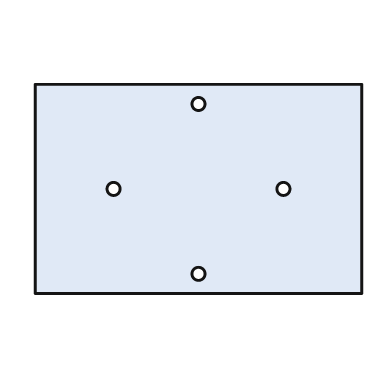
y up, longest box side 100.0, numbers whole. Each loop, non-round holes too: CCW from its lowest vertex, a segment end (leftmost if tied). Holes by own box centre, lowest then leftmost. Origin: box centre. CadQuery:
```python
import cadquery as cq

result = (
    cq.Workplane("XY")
    .moveTo(-50.0, -32.0)
    .lineTo(50.0, -32.0)
    .lineTo(50.0, 32.0)
    .lineTo(-50.0, 32.0)
    .close()
    .moveTo(0.0, -26.0)
    .circle(2.0)
    .moveTo(-26.0, 0.0)
    .circle(2.0)
    .moveTo(26.0, 0.0)
    .circle(2.0)
    .moveTo(0.0, 26.0)
    .circle(2.0)
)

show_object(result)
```